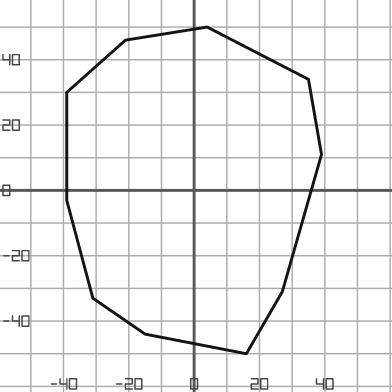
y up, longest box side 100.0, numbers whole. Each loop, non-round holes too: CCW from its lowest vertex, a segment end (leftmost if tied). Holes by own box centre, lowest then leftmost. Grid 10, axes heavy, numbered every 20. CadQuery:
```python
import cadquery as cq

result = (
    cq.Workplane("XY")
    .moveTo(16.0, -50.0)
    .lineTo(27.0, -31.0)
    .lineTo(39.0, 11.0)
    .lineTo(35.0, 34.0)
    .lineTo(4.0, 50.0)
    .lineTo(-21.0, 46.0)
    .lineTo(-39.0, 30.0)
    .lineTo(-39.0, -3.0)
    .lineTo(-31.0, -33.0)
    .lineTo(-15.0, -44.0)
    .close()
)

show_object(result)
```